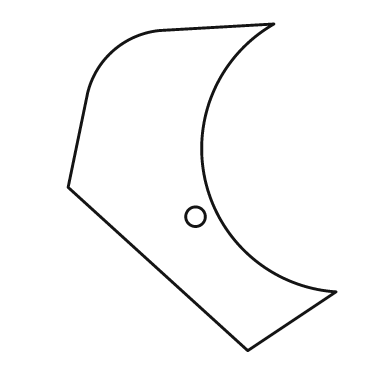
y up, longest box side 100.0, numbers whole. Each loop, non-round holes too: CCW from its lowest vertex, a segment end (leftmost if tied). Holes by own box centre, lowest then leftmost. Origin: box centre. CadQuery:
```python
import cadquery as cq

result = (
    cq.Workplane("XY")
    .moveTo(14.0, -50.0)
    .lineTo(41.0, -32.0)
    .threePointArc((1.0, 2.0), (22.0, 50.0))
    .lineTo(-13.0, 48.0)
    .threePointArc((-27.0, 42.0), (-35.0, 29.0))
    .lineTo(-41.0, 0.0)
    .close()
    .moveTo(-2.0, -9.0)
    .circle(3.0)
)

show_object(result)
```